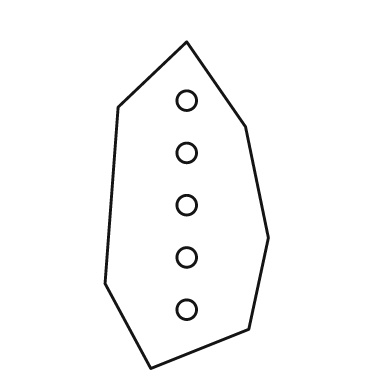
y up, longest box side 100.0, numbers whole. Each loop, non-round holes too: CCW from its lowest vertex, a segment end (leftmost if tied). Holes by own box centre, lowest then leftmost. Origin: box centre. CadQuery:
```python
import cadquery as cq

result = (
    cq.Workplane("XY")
    .moveTo(-11.0, -50.0)
    .lineTo(19.0, -38.0)
    .lineTo(25.0, -10.0)
    .lineTo(18.0, 24.0)
    .lineTo(0.0, 50.0)
    .lineTo(-21.0, 30.0)
    .lineTo(-25.0, -24.0)
    .close()
    .moveTo(0.0, -32.0)
    .circle(3.0)
    .moveTo(0.0, -16.0)
    .circle(3.0)
    .moveTo(0.0, 0.0)
    .circle(3.0)
    .moveTo(0.0, 16.0)
    .circle(3.0)
    .moveTo(0.0, 32.0)
    .circle(3.0)
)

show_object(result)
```